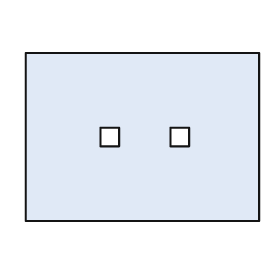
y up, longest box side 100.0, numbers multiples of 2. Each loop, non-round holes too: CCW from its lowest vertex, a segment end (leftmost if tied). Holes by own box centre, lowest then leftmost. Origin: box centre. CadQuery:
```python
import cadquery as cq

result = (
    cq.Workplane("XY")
    .moveTo(-50.0, -36.0)
    .lineTo(50.0, -36.0)
    .lineTo(50.0, 36.0)
    .lineTo(-50.0, 36.0)
    .close()
    .moveTo(-18.0, -4.0)
    .lineTo(-10.0, -4.0)
    .lineTo(-10.0, 4.0)
    .lineTo(-18.0, 4.0)
    .close()
    .moveTo(12.0, -4.0)
    .lineTo(20.0, -4.0)
    .lineTo(20.0, 4.0)
    .lineTo(12.0, 4.0)
    .close()
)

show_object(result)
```